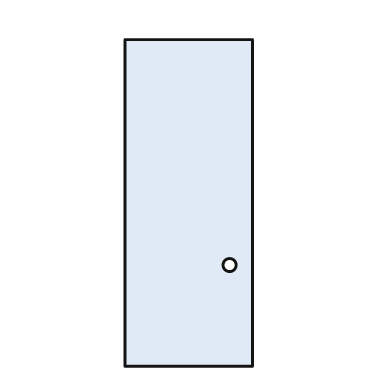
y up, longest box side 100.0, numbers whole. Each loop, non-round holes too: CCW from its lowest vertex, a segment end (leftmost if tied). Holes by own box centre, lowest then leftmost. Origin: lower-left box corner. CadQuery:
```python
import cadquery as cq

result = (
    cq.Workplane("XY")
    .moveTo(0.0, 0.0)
    .lineTo(39.0, 0.0)
    .lineTo(39.0, 100.0)
    .lineTo(0.0, 100.0)
    .close()
    .moveTo(32.0, 31.0)
    .circle(2.0)
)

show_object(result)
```